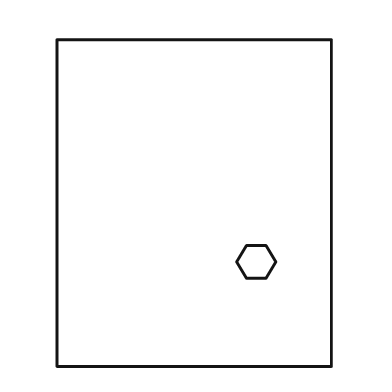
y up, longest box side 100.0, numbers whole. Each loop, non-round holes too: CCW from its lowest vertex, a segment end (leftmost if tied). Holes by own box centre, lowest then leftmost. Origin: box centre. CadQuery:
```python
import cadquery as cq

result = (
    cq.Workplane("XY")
    .moveTo(-42.0, -50.0)
    .lineTo(42.0, -50.0)
    .lineTo(42.0, 50.0)
    .lineTo(-42.0, 50.0)
    .close()
    .moveTo(16.0, -23.0)
    .lineTo(22.0, -23.0)
    .lineTo(25.0, -18.0)
    .lineTo(22.0, -13.0)
    .lineTo(16.0, -13.0)
    .lineTo(13.0, -18.0)
    .close()
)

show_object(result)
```